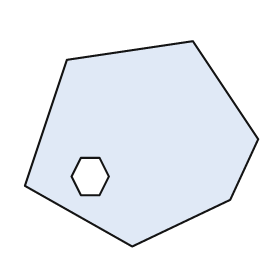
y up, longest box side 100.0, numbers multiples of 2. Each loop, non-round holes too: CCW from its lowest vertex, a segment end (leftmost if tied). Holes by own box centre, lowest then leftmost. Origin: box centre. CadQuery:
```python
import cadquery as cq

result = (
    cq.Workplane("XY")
    .moveTo(-4.0, -44.0)
    .lineTo(38.0, -24.0)
    .lineTo(50.0, 2.0)
    .lineTo(22.0, 44.0)
    .lineTo(-32.0, 36.0)
    .lineTo(-50.0, -18.0)
    .close()
    .moveTo(-26.0, -22.0)
    .lineTo(-18.0, -22.0)
    .lineTo(-14.0, -14.0)
    .lineTo(-18.0, -6.0)
    .lineTo(-26.0, -6.0)
    .lineTo(-30.0, -14.0)
    .close()
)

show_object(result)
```